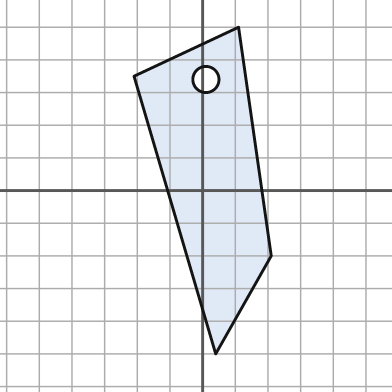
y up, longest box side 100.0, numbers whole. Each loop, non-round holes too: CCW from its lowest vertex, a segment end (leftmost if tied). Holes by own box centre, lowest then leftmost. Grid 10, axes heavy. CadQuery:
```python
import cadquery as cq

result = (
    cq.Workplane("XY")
    .moveTo(4.0, -50.0)
    .lineTo(21.0, -20.0)
    .lineTo(11.0, 50.0)
    .lineTo(-21.0, 35.0)
    .close()
    .moveTo(1.0, 34.0)
    .circle(4.0)
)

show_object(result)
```